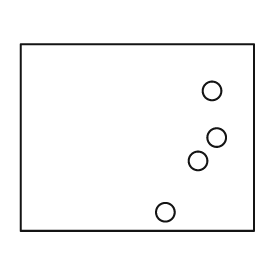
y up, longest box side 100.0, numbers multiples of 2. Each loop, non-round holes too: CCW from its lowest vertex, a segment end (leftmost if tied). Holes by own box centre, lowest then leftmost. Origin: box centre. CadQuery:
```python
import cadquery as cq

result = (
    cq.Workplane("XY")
    .moveTo(-50.0, -40.0)
    .lineTo(50.0, -40.0)
    .lineTo(50.0, 40.0)
    .lineTo(-50.0, 40.0)
    .close()
    .moveTo(12.0, -32.0)
    .circle(4.0)
    .moveTo(26.0, -10.0)
    .circle(4.0)
    .moveTo(34.0, 0.0)
    .circle(4.0)
    .moveTo(32.0, 20.0)
    .circle(4.0)
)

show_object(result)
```